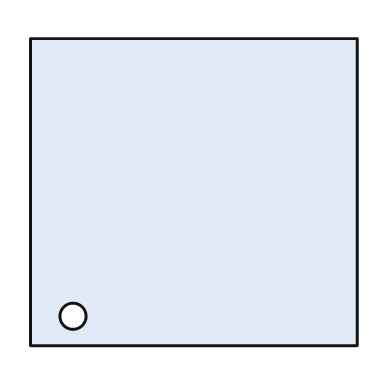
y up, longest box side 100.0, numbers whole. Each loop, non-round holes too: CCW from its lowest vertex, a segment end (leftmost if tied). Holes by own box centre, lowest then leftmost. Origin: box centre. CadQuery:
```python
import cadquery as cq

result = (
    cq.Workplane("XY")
    .moveTo(-50.0, -47.0)
    .lineTo(50.0, -47.0)
    .lineTo(50.0, 47.0)
    .lineTo(-50.0, 47.0)
    .close()
    .moveTo(-37.0, -38.0)
    .circle(4.0)
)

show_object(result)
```